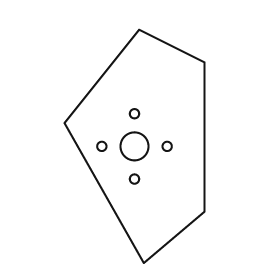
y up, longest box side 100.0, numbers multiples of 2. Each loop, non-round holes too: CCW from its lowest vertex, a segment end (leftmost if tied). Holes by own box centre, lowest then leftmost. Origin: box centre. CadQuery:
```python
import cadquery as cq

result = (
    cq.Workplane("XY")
    .moveTo(4.0, -50.0)
    .lineTo(30.0, -28.0)
    .lineTo(30.0, 36.0)
    .lineTo(2.0, 50.0)
    .lineTo(-30.0, 10.0)
    .close()
    .moveTo(0.0, -14.0)
    .circle(2.0)
    .moveTo(-14.0, 0.0)
    .circle(2.0)
    .moveTo(0.0, 0.0)
    .circle(6.0)
    .moveTo(14.0, 0.0)
    .circle(2.0)
    .moveTo(0.0, 14.0)
    .circle(2.0)
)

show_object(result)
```